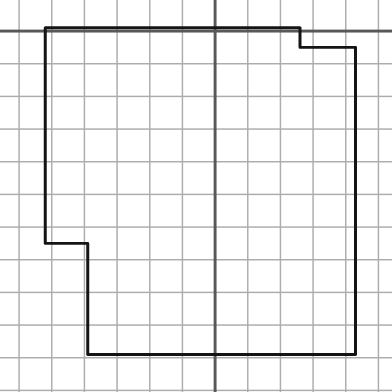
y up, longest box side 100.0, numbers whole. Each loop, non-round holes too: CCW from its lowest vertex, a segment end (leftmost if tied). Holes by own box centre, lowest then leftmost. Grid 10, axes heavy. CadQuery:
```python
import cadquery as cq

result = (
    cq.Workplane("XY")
    .moveTo(-39.0, -99.0)
    .lineTo(43.0, -99.0)
    .lineTo(43.0, -5.0)
    .lineTo(26.0, -5.0)
    .lineTo(26.0, 1.0)
    .lineTo(-52.0, 1.0)
    .lineTo(-52.0, -65.0)
    .lineTo(-39.0, -65.0)
    .close()
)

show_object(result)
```